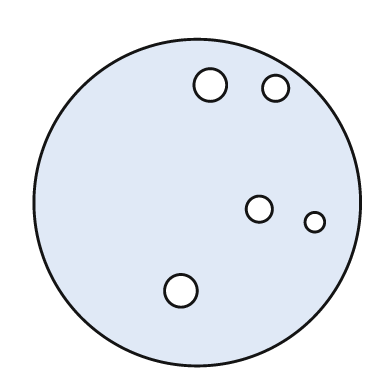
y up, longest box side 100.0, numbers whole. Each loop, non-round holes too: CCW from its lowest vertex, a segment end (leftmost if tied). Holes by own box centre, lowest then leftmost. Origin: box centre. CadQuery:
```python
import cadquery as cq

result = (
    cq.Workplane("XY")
    .moveTo(0.0, 0.0)
    .circle(50.0)
    .moveTo(-5.0, -27.0)
    .circle(5.0)
    .moveTo(36.0, -6.0)
    .circle(3.0)
    .moveTo(19.0, -2.0)
    .circle(4.0)
    .moveTo(24.0, 35.0)
    .circle(4.0)
    .moveTo(4.0, 36.0)
    .circle(5.0)
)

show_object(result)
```